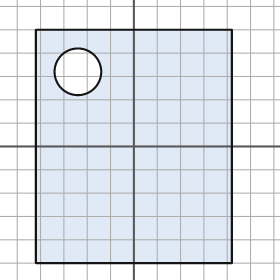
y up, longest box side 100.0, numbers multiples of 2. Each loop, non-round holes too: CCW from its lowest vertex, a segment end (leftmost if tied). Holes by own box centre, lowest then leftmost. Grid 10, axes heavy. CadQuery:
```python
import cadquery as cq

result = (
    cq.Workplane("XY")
    .moveTo(-42.0, -50.0)
    .lineTo(42.0, -50.0)
    .lineTo(42.0, 50.0)
    .lineTo(-42.0, 50.0)
    .close()
    .moveTo(-24.0, 32.0)
    .circle(10.0)
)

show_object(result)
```